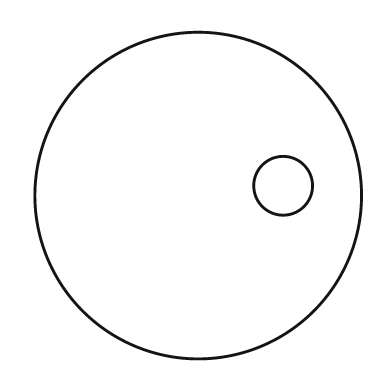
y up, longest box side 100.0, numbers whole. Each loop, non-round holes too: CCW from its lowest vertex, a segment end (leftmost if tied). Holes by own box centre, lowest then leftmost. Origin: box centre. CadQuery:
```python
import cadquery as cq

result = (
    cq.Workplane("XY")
    .moveTo(0.0, 0.0)
    .circle(50.0)
    .moveTo(26.0, 3.0)
    .circle(9.0)
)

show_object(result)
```